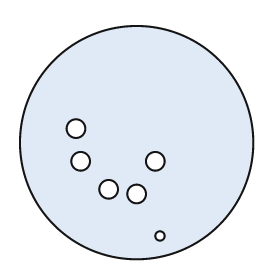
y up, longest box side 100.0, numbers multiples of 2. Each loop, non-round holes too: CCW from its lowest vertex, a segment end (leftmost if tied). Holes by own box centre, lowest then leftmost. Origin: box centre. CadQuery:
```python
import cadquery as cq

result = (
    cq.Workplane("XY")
    .moveTo(0.0, 0.0)
    .circle(50.0)
    .moveTo(10.0, -40.0)
    .circle(2.0)
    .moveTo(0.0, -22.0)
    .circle(4.0)
    .moveTo(-12.0, -20.0)
    .circle(4.0)
    .moveTo(-24.0, -8.0)
    .circle(4.0)
    .moveTo(8.0, -8.0)
    .circle(4.0)
    .moveTo(-26.0, 6.0)
    .circle(4.0)
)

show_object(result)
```